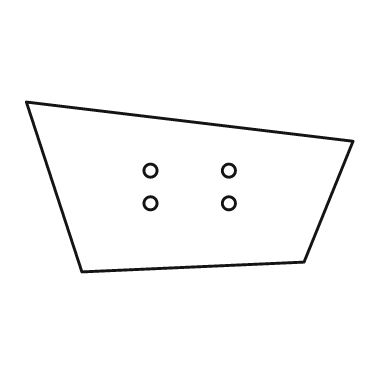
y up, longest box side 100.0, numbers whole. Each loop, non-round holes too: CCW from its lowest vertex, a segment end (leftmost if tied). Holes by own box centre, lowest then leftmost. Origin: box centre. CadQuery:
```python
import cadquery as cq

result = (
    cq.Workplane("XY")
    .moveTo(-33.0, -26.0)
    .lineTo(35.0, -23.0)
    .lineTo(50.0, 14.0)
    .lineTo(-50.0, 26.0)
    .close()
    .moveTo(-12.0, -5.0)
    .circle(2.0)
    .moveTo(12.0, -5.0)
    .circle(2.0)
    .moveTo(-12.0, 5.0)
    .circle(2.0)
    .moveTo(12.0, 5.0)
    .circle(2.0)
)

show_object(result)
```